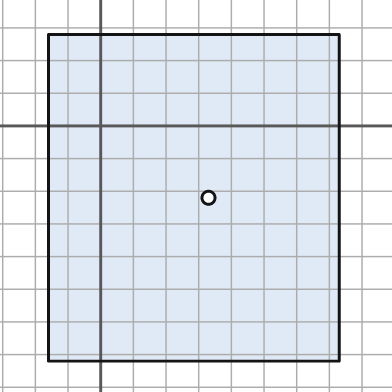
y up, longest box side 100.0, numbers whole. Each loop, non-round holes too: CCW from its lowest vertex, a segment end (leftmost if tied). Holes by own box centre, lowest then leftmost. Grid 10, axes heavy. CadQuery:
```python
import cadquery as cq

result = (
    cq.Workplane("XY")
    .moveTo(-16.0, -72.0)
    .lineTo(73.0, -72.0)
    .lineTo(73.0, 28.0)
    .lineTo(-16.0, 28.0)
    .close()
    .moveTo(33.0, -22.0)
    .circle(2.0)
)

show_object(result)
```